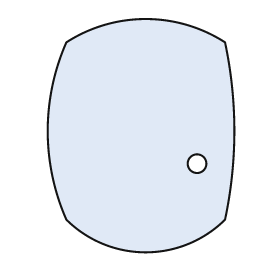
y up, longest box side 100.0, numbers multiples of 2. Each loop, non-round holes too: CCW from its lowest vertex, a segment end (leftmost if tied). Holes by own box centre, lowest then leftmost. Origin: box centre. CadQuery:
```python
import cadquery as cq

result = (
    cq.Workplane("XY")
    .moveTo(-32.0, -36.0)
    .threePointArc((2.0, -50.0), (36.0, -36.0))
    .threePointArc((40.0, 2.0), (36.0, 40.0))
    .threePointArc((2.0, 50.0), (-32.0, 40.0))
    .threePointArc((-40.0, 2.0), (-32.0, -36.0))
    .close()
    .moveTo(24.0, -12.0)
    .circle(4.0)
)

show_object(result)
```